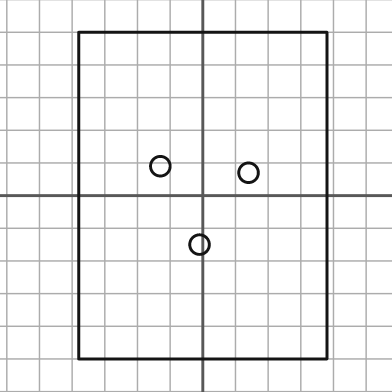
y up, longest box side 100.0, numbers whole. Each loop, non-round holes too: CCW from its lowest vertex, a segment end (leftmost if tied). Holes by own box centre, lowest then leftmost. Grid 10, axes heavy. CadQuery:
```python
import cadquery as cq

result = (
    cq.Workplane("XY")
    .moveTo(-38.0, -50.0)
    .lineTo(38.0, -50.0)
    .lineTo(38.0, 50.0)
    .lineTo(-38.0, 50.0)
    .close()
    .moveTo(-1.0, -15.0)
    .circle(3.0)
    .moveTo(14.0, 7.0)
    .circle(3.0)
    .moveTo(-13.0, 9.0)
    .circle(3.0)
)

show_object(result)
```